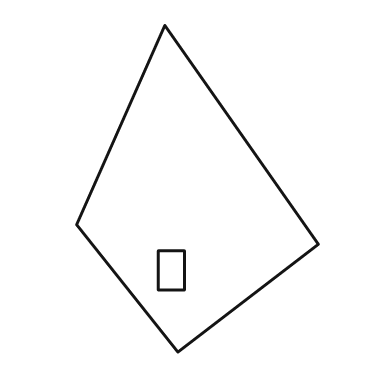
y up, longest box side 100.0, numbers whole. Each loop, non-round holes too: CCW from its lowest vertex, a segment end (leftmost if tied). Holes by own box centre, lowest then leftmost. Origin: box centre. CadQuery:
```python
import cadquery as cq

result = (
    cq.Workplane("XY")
    .moveTo(-6.0, -50.0)
    .lineTo(37.0, -17.0)
    .lineTo(-10.0, 50.0)
    .lineTo(-37.0, -11.0)
    .close()
    .moveTo(-12.0, -31.0)
    .lineTo(-4.0, -31.0)
    .lineTo(-4.0, -19.0)
    .lineTo(-12.0, -19.0)
    .close()
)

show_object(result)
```